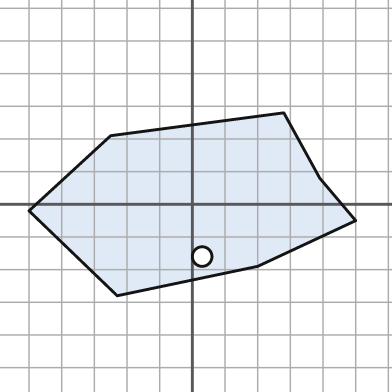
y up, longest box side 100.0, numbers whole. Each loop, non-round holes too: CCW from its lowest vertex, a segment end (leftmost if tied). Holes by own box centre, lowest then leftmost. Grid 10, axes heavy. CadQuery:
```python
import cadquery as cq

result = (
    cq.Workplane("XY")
    .moveTo(-23.0, -28.0)
    .lineTo(20.0, -19.0)
    .lineTo(50.0, -5.0)
    .lineTo(39.0, 8.0)
    .lineTo(28.0, 28.0)
    .lineTo(-25.0, 21.0)
    .lineTo(-50.0, -2.0)
    .close()
    .moveTo(3.0, -16.0)
    .circle(3.0)
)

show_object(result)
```